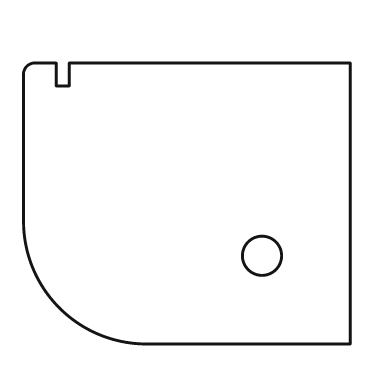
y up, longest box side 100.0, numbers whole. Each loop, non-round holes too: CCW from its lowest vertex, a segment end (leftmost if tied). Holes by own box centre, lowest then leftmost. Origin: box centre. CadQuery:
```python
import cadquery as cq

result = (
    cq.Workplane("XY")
    .moveTo(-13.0, -43.0)
    .lineTo(50.0, -43.0)
    .lineTo(50.0, 43.0)
    .lineTo(-36.0, 43.0)
    .lineTo(-36.0, 36.0)
    .lineTo(-40.0, 36.0)
    .lineTo(-40.0, 43.0)
    .lineTo(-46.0, 43.0)
    .threePointArc((-49.0, 42.0), (-50.0, 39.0))
    .lineTo(-50.0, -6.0)
    .threePointArc((-39.0, -32.0), (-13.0, -43.0))
    .close()
    .moveTo(23.0, -16.0)
    .circle(6.0)
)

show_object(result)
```